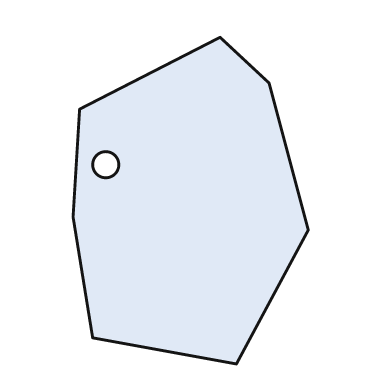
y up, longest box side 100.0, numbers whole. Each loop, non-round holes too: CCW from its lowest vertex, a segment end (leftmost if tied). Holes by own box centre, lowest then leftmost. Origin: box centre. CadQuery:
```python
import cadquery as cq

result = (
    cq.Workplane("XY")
    .moveTo(14.0, -50.0)
    .lineTo(36.0, -9.0)
    .lineTo(24.0, 36.0)
    .lineTo(9.0, 50.0)
    .lineTo(-34.0, 28.0)
    .lineTo(-36.0, -5.0)
    .lineTo(-30.0, -42.0)
    .close()
    .moveTo(-26.0, 11.0)
    .circle(4.0)
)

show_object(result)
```